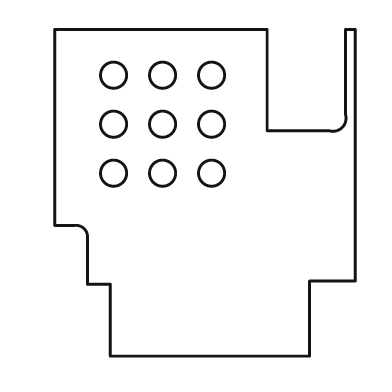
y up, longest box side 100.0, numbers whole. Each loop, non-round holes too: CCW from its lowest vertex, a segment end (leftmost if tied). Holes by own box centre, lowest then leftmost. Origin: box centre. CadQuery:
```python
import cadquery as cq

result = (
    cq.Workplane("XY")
    .moveTo(-29.0, -50.0)
    .lineTo(32.0, -50.0)
    .lineTo(32.0, -27.0)
    .lineTo(46.0, -27.0)
    .lineTo(46.0, 50.0)
    .lineTo(43.0, 50.0)
    .lineTo(43.0, 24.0)
    .threePointArc((42.0, 20.0), (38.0, 19.0))
    .lineTo(19.0, 19.0)
    .lineTo(19.0, 50.0)
    .lineTo(-46.0, 50.0)
    .lineTo(-46.0, -10.0)
    .lineTo(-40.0, -10.0)
    .threePointArc((-37.0, -11.0), (-36.0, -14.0))
    .lineTo(-36.0, -28.0)
    .lineTo(-29.0, -28.0)
    .close()
    .moveTo(-28.0, 6.0)
    .circle(4.0)
    .moveTo(-13.0, 6.0)
    .circle(4.0)
    .moveTo(2.0, 6.0)
    .circle(4.0)
    .moveTo(-28.0, 21.0)
    .circle(4.0)
    .moveTo(-13.0, 21.0)
    .circle(4.0)
    .moveTo(2.0, 21.0)
    .circle(4.0)
    .moveTo(-28.0, 36.0)
    .circle(4.0)
    .moveTo(-13.0, 36.0)
    .circle(4.0)
    .moveTo(2.0, 36.0)
    .circle(4.0)
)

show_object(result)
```